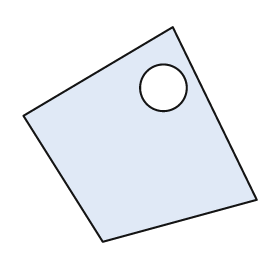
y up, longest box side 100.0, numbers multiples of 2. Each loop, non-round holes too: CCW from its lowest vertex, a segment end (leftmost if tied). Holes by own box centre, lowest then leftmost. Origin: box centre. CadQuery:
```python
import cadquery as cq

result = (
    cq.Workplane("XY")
    .moveTo(-16.0, -46.0)
    .lineTo(50.0, -28.0)
    .lineTo(14.0, 46.0)
    .lineTo(-50.0, 8.0)
    .close()
    .moveTo(10.0, 20.0)
    .circle(10.0)
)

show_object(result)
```